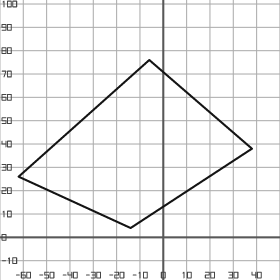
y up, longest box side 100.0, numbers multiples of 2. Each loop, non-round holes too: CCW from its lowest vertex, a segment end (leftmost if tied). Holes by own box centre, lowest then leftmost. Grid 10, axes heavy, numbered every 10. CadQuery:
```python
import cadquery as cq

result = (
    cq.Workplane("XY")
    .moveTo(-14.0, 4.0)
    .lineTo(38.0, 38.0)
    .lineTo(-6.0, 76.0)
    .lineTo(-62.0, 26.0)
    .close()
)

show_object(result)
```